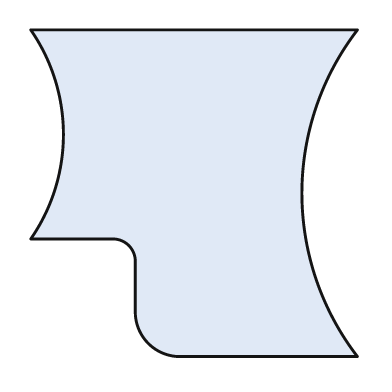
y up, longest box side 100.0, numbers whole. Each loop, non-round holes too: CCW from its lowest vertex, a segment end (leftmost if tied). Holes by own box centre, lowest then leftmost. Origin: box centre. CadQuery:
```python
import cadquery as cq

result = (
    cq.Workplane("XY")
    .moveTo(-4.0, -50.0)
    .lineTo(50.0, -50.0)
    .threePointArc((33.0, 0.0), (50.0, 50.0))
    .lineTo(-50.0, 50.0)
    .threePointArc((-40.0, 18.0), (-50.0, -14.0))
    .lineTo(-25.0, -14.0)
    .threePointArc((-20.0, -16.0), (-18.0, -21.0))
    .lineTo(-18.0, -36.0)
    .threePointArc((-14.0, -46.0), (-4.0, -50.0))
    .close()
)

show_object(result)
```